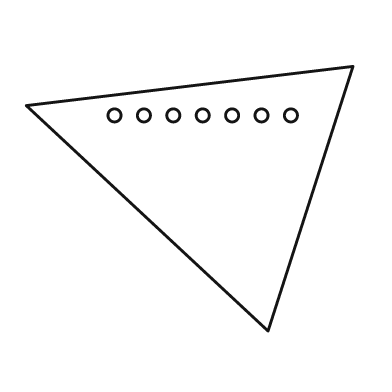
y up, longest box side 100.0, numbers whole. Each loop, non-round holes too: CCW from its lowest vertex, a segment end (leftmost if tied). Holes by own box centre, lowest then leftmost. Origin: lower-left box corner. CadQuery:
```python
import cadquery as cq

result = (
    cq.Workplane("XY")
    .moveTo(74.0, 0.0)
    .lineTo(100.0, 81.0)
    .lineTo(0.0, 69.0)
    .close()
    .moveTo(27.0, 66.0)
    .circle(2.0)
    .moveTo(36.0, 66.0)
    .circle(2.0)
    .moveTo(45.0, 66.0)
    .circle(2.0)
    .moveTo(54.0, 66.0)
    .circle(2.0)
    .moveTo(63.0, 66.0)
    .circle(2.0)
    .moveTo(72.0, 66.0)
    .circle(2.0)
    .moveTo(81.0, 66.0)
    .circle(2.0)
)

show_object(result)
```